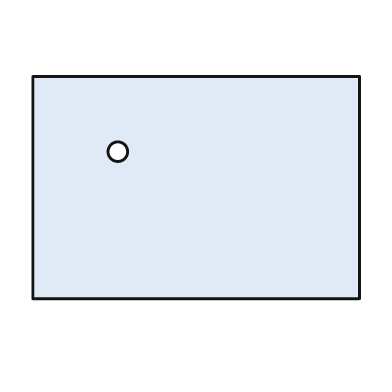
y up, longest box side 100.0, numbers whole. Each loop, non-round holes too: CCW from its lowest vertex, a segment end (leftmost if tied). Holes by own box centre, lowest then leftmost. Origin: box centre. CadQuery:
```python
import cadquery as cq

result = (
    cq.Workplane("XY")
    .moveTo(-50.0, -34.0)
    .lineTo(50.0, -34.0)
    .lineTo(50.0, 34.0)
    .lineTo(-50.0, 34.0)
    .close()
    .moveTo(-24.0, 11.0)
    .circle(3.0)
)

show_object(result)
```